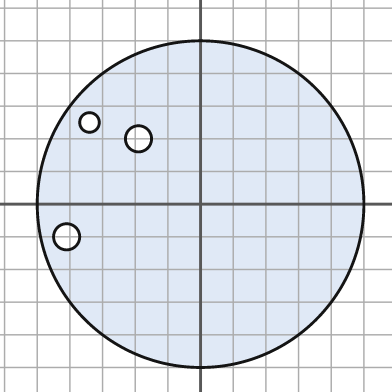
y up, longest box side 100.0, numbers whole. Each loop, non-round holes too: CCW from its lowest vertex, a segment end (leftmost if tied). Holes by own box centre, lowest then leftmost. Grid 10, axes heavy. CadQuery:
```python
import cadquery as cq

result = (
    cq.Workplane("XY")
    .moveTo(0.0, 0.0)
    .circle(50.0)
    .moveTo(-41.0, -10.0)
    .circle(4.0)
    .moveTo(-19.0, 20.0)
    .circle(4.0)
    .moveTo(-34.0, 25.0)
    .circle(3.0)
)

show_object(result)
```